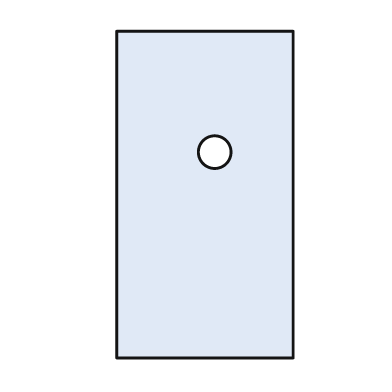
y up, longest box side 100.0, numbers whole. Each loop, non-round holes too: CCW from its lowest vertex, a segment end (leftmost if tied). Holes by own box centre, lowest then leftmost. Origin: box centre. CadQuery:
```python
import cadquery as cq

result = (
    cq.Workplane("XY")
    .moveTo(-27.0, -50.0)
    .lineTo(27.0, -50.0)
    .lineTo(27.0, 50.0)
    .lineTo(-27.0, 50.0)
    .close()
    .moveTo(3.0, 13.0)
    .circle(5.0)
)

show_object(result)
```